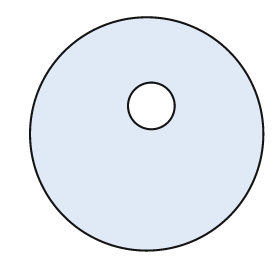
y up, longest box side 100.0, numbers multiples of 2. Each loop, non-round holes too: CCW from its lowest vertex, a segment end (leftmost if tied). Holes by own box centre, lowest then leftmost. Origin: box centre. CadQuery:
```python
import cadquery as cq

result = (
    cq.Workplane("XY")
    .moveTo(0.0, 0.0)
    .circle(50.0)
    .moveTo(2.0, 12.0)
    .circle(10.0)
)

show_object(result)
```